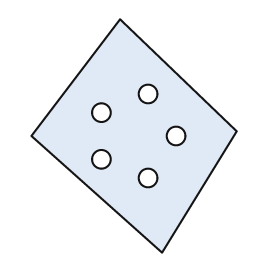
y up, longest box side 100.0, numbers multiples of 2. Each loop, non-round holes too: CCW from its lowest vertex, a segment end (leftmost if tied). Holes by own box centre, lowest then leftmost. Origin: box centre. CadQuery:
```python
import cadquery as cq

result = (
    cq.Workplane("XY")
    .moveTo(12.0, -50.0)
    .lineTo(44.0, 2.0)
    .lineTo(-6.0, 50.0)
    .lineTo(-44.0, 0.0)
    .close()
    .moveTo(6.0, -18.0)
    .circle(4.0)
    .moveTo(-14.0, -10.0)
    .circle(4.0)
    .moveTo(18.0, 0.0)
    .circle(4.0)
    .moveTo(-14.0, 10.0)
    .circle(4.0)
    .moveTo(6.0, 18.0)
    .circle(4.0)
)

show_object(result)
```